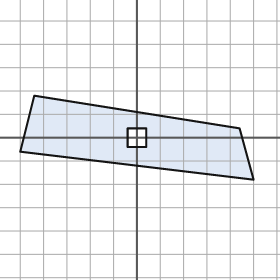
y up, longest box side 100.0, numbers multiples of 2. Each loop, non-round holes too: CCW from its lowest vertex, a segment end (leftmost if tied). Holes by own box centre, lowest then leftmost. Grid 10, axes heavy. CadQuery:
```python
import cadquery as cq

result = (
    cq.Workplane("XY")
    .moveTo(50.0, -18.0)
    .lineTo(44.0, 4.0)
    .lineTo(-44.0, 18.0)
    .lineTo(-50.0, -6.0)
    .close()
    .moveTo(-4.0, -4.0)
    .lineTo(4.0, -4.0)
    .lineTo(4.0, 4.0)
    .lineTo(-4.0, 4.0)
    .close()
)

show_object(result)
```